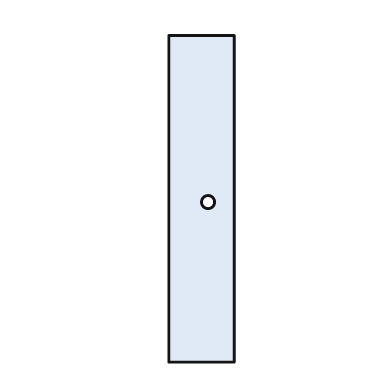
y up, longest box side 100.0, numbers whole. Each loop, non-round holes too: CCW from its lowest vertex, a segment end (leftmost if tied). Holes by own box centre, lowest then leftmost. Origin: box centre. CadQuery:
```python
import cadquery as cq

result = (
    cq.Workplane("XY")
    .moveTo(-10.0, -50.0)
    .lineTo(10.0, -50.0)
    .lineTo(10.0, 50.0)
    .lineTo(-10.0, 50.0)
    .close()
    .moveTo(2.0, -1.0)
    .circle(2.0)
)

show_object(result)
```